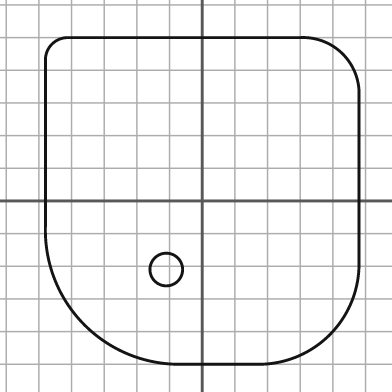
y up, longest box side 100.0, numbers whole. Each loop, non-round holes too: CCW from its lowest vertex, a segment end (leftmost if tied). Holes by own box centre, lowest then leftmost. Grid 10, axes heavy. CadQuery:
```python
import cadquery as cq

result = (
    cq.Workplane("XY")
    .moveTo(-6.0, -50.0)
    .lineTo(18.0, -50.0)
    .threePointArc((39.0, -41.0), (48.0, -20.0))
    .lineTo(48.0, 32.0)
    .threePointArc((43.0, 45.0), (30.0, 50.0))
    .lineTo(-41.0, 50.0)
    .threePointArc((-46.0, 48.0), (-48.0, 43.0))
    .lineTo(-48.0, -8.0)
    .threePointArc((-36.0, -38.0), (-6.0, -50.0))
    .close()
    .moveTo(-11.0, -21.0)
    .circle(5.0)
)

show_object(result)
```